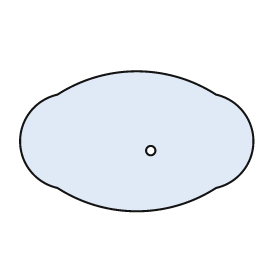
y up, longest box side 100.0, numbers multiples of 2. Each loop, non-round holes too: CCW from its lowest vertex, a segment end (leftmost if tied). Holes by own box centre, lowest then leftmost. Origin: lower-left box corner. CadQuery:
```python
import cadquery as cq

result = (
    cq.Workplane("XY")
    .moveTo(16.0, 10.0)
    .threePointArc((50.0, 0.0), (84.0, 10.0))
    .threePointArc((100.0, 30.0), (84.0, 50.0))
    .threePointArc((50.0, 60.0), (16.0, 50.0))
    .threePointArc((0.0, 30.0), (16.0, 10.0))
    .close()
    .moveTo(56.0, 26.0)
    .circle(2.0)
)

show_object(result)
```